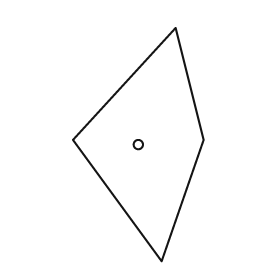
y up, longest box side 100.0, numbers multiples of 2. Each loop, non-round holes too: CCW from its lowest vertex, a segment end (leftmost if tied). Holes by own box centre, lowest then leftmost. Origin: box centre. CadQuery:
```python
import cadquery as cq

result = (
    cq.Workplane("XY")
    .moveTo(10.0, -50.0)
    .lineTo(28.0, 2.0)
    .lineTo(16.0, 50.0)
    .lineTo(-28.0, 2.0)
    .close()
    .moveTo(0.0, 0.0)
    .circle(2.0)
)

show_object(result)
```